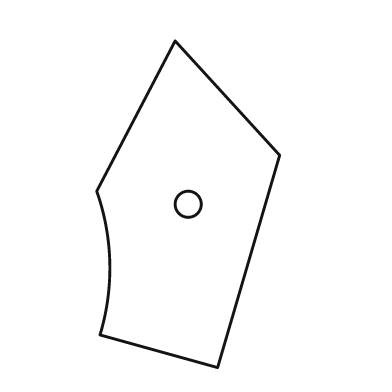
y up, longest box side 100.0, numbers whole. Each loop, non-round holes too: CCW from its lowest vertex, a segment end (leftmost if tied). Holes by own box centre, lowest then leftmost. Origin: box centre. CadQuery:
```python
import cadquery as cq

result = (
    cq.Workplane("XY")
    .moveTo(9.0, -50.0)
    .lineTo(28.0, 15.0)
    .lineTo(-4.0, 50.0)
    .lineTo(-28.0, 4.0)
    .threePointArc((-24.0, -18.0), (-27.0, -40.0))
    .close()
    .moveTo(0.0, 0.0)
    .circle(4.0)
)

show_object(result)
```